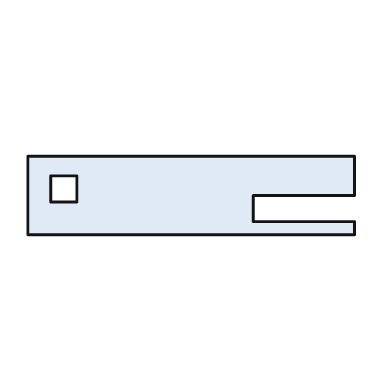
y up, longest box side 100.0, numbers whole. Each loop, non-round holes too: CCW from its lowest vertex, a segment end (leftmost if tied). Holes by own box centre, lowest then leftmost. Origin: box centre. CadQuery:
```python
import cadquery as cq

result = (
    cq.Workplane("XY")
    .moveTo(-50.0, -12.0)
    .lineTo(50.0, -12.0)
    .lineTo(50.0, -8.0)
    .lineTo(19.0, -8.0)
    .lineTo(19.0, 0.0)
    .lineTo(50.0, 0.0)
    .lineTo(50.0, 12.0)
    .lineTo(-50.0, 12.0)
    .close()
    .moveTo(-43.0, -2.0)
    .lineTo(-35.0, -2.0)
    .lineTo(-35.0, 6.0)
    .lineTo(-43.0, 6.0)
    .close()
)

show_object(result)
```